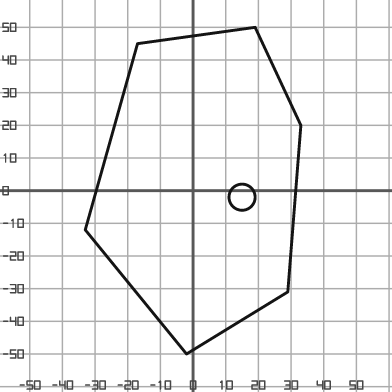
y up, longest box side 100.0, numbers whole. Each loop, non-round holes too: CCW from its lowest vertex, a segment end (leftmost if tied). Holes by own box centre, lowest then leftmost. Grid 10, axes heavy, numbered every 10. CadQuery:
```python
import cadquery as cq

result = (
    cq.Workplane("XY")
    .moveTo(-2.0, -50.0)
    .lineTo(29.0, -31.0)
    .lineTo(33.0, 20.0)
    .lineTo(19.0, 50.0)
    .lineTo(-17.0, 45.0)
    .lineTo(-33.0, -12.0)
    .close()
    .moveTo(15.0, -2.0)
    .circle(4.0)
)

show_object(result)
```